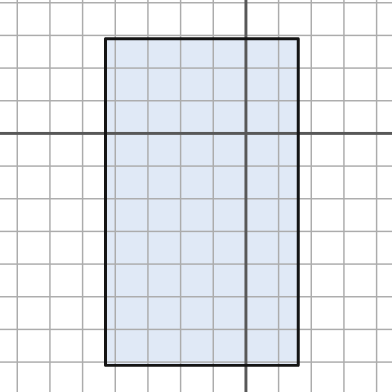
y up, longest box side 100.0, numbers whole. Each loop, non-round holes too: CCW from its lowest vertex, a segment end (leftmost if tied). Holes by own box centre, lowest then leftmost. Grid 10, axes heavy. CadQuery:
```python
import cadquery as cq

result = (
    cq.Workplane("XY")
    .moveTo(-43.0, -71.0)
    .lineTo(16.0, -71.0)
    .lineTo(16.0, 29.0)
    .lineTo(-43.0, 29.0)
    .close()
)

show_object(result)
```